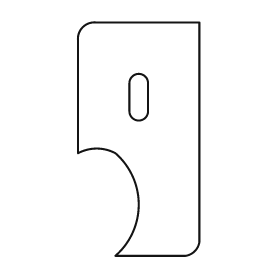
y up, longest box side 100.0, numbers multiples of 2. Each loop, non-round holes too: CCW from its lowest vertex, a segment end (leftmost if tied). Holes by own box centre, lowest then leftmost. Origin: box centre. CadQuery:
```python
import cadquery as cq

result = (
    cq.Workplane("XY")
    .moveTo(-10.0, -50.0)
    .lineTo(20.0, -50.0)
    .threePointArc((24.0, -48.0), (26.0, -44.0))
    .lineTo(26.0, 50.0)
    .lineTo(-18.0, 50.0)
    .threePointArc((-24.0, 48.0), (-26.0, 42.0))
    .lineTo(-26.0, -6.0)
    .threePointArc((-18.0, -4.0), (-10.0, -6.0))
    .threePointArc((0.0, -28.0), (-10.0, -50.0))
    .close()
    .moveTo(-4.0, 12.0)
    .threePointArc((0.0, 8.0), (4.0, 12.0))
    .lineTo(4.0, 24.0)
    .threePointArc((0.0, 28.0), (-4.0, 24.0))
    .close()
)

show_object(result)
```